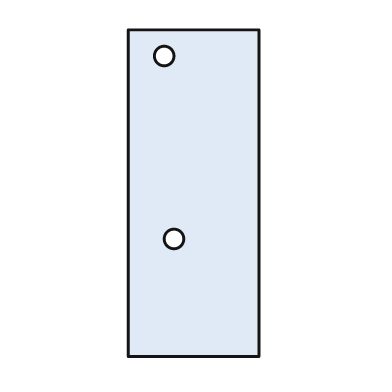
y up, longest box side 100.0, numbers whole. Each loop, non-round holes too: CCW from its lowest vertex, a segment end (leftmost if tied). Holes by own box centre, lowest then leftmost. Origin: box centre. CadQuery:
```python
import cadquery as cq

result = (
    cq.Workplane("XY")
    .moveTo(-20.0, -50.0)
    .lineTo(20.0, -50.0)
    .lineTo(20.0, 50.0)
    .lineTo(-20.0, 50.0)
    .close()
    .moveTo(-6.0, -14.0)
    .circle(3.0)
    .moveTo(-9.0, 42.0)
    .circle(3.0)
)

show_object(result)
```